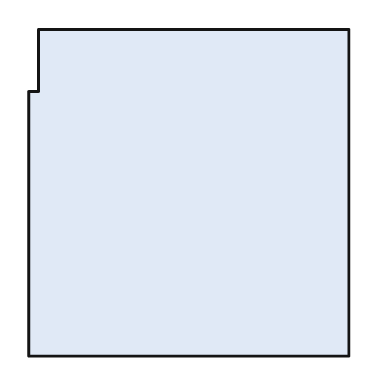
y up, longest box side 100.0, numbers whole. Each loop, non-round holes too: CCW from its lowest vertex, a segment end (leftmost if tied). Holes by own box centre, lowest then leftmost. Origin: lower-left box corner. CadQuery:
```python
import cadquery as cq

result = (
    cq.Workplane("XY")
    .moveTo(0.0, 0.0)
    .lineTo(98.0, 0.0)
    .lineTo(98.0, 100.0)
    .lineTo(3.0, 100.0)
    .lineTo(3.0, 81.0)
    .lineTo(0.0, 81.0)
    .close()
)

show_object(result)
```